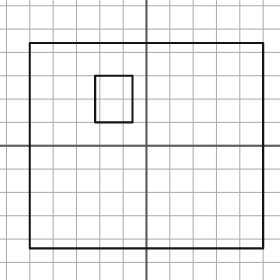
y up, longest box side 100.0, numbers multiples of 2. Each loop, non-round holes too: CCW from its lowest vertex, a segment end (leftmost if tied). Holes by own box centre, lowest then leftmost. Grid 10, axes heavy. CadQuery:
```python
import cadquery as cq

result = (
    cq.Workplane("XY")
    .moveTo(-50.0, -44.0)
    .lineTo(50.0, -44.0)
    .lineTo(50.0, 44.0)
    .lineTo(-50.0, 44.0)
    .close()
    .moveTo(-22.0, 10.0)
    .lineTo(-6.0, 10.0)
    .lineTo(-6.0, 30.0)
    .lineTo(-22.0, 30.0)
    .close()
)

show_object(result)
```